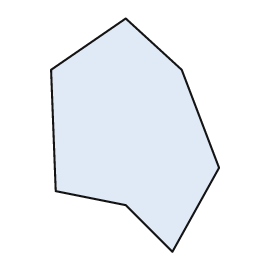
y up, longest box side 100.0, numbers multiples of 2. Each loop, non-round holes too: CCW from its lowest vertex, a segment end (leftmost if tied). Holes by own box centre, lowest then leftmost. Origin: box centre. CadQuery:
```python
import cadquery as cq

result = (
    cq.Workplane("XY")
    .moveTo(16.0, -50.0)
    .lineTo(36.0, -14.0)
    .lineTo(20.0, 28.0)
    .lineTo(-4.0, 50.0)
    .lineTo(-36.0, 28.0)
    .lineTo(-34.0, -24.0)
    .lineTo(-4.0, -30.0)
    .close()
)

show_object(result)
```